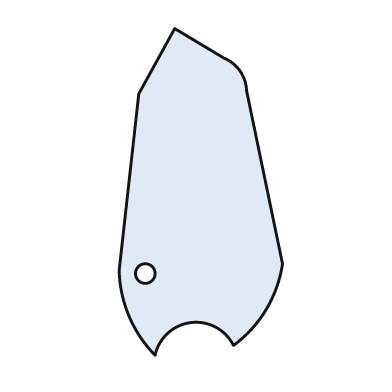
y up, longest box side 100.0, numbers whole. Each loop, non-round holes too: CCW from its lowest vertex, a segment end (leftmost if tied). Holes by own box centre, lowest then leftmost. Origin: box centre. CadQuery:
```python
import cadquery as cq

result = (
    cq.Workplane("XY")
    .moveTo(-14.0, -50.0)
    .threePointArc((-3.0, -40.0), (10.0, -47.0))
    .threePointArc((20.0, -36.0), (25.0, -22.0))
    .lineTo(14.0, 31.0)
    .threePointArc((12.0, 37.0), (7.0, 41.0))
    .lineTo(-8.0, 50.0)
    .lineTo(-19.0, 30.0)
    .lineTo(-25.0, -24.0)
    .threePointArc((-22.0, -38.0), (-14.0, -50.0))
    .close()
    .moveTo(-17.0, -25.0)
    .circle(3.0)
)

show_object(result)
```